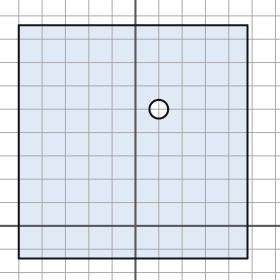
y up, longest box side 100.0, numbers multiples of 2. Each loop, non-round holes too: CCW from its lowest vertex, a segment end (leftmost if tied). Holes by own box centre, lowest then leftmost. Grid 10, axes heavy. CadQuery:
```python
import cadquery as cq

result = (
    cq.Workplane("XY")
    .moveTo(-50.0, -14.0)
    .lineTo(48.0, -14.0)
    .lineTo(48.0, 86.0)
    .lineTo(-50.0, 86.0)
    .close()
    .moveTo(10.0, 50.0)
    .circle(4.0)
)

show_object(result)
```